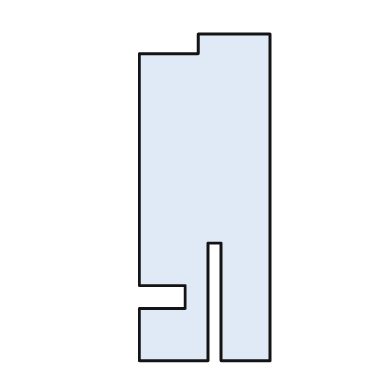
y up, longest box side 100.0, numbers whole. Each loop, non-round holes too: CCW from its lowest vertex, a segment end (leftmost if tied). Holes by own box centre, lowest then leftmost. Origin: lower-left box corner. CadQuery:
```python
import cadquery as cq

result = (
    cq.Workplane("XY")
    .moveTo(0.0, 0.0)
    .lineTo(21.0, 0.0)
    .lineTo(21.0, 36.0)
    .lineTo(25.0, 36.0)
    .lineTo(25.0, 0.0)
    .lineTo(40.0, 0.0)
    .lineTo(40.0, 100.0)
    .lineTo(18.0, 100.0)
    .lineTo(18.0, 94.0)
    .lineTo(0.0, 94.0)
    .lineTo(0.0, 23.0)
    .lineTo(14.0, 23.0)
    .lineTo(14.0, 16.0)
    .lineTo(0.0, 16.0)
    .close()
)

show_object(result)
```